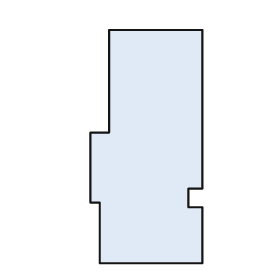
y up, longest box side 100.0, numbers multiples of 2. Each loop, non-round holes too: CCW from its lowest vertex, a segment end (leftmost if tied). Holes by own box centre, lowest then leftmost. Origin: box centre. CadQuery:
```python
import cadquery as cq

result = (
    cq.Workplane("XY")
    .moveTo(-20.0, -50.0)
    .lineTo(24.0, -50.0)
    .lineTo(24.0, -26.0)
    .lineTo(18.0, -26.0)
    .lineTo(18.0, -18.0)
    .lineTo(24.0, -18.0)
    .lineTo(24.0, 50.0)
    .lineTo(-16.0, 50.0)
    .lineTo(-16.0, 6.0)
    .lineTo(-24.0, 6.0)
    .lineTo(-24.0, -24.0)
    .lineTo(-20.0, -24.0)
    .close()
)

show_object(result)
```